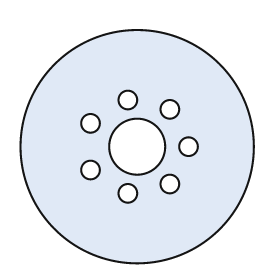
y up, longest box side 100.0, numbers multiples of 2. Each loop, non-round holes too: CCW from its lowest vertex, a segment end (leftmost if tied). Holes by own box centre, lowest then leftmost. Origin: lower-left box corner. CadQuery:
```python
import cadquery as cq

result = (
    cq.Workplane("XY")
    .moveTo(50.0, 50.0)
    .circle(50.0)
    .moveTo(46.0, 30.0)
    .circle(4.0)
    .moveTo(64.0, 34.0)
    .circle(4.0)
    .moveTo(30.0, 40.0)
    .circle(4.0)
    .moveTo(50.0, 50.0)
    .circle(12.0)
    .moveTo(72.0, 50.0)
    .circle(4.0)
    .moveTo(30.0, 60.0)
    .circle(4.0)
    .moveTo(64.0, 66.0)
    .circle(4.0)
    .moveTo(46.0, 70.0)
    .circle(4.0)
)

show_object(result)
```